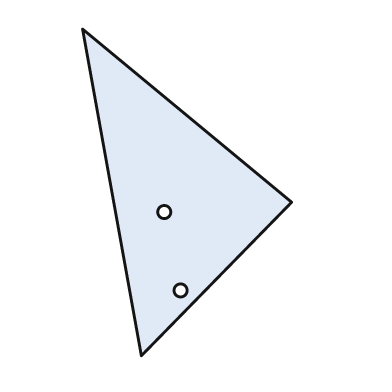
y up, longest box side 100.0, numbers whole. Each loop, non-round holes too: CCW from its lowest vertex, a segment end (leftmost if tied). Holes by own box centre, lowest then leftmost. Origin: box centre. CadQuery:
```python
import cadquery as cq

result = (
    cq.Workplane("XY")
    .moveTo(-14.0, -50.0)
    .lineTo(32.0, -3.0)
    .lineTo(-32.0, 50.0)
    .close()
    .moveTo(-2.0, -30.0)
    .circle(2.0)
    .moveTo(-7.0, -6.0)
    .circle(2.0)
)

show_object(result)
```